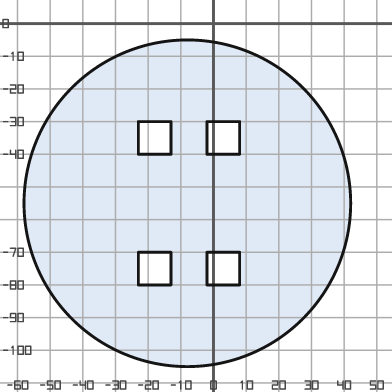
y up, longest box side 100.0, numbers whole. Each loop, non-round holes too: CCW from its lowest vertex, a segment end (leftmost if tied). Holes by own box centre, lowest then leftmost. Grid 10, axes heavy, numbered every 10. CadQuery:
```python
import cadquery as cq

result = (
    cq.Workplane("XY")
    .moveTo(-8.0, -55.0)
    .circle(50.0)
    .moveTo(-23.0, -80.0)
    .lineTo(-13.0, -80.0)
    .lineTo(-13.0, -70.0)
    .lineTo(-23.0, -70.0)
    .close()
    .moveTo(-2.0, -80.0)
    .lineTo(8.0, -80.0)
    .lineTo(8.0, -70.0)
    .lineTo(-2.0, -70.0)
    .close()
    .moveTo(-23.0, -40.0)
    .lineTo(-13.0, -40.0)
    .lineTo(-13.0, -30.0)
    .lineTo(-23.0, -30.0)
    .close()
    .moveTo(-2.0, -40.0)
    .lineTo(8.0, -40.0)
    .lineTo(8.0, -30.0)
    .lineTo(-2.0, -30.0)
    .close()
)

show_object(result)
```